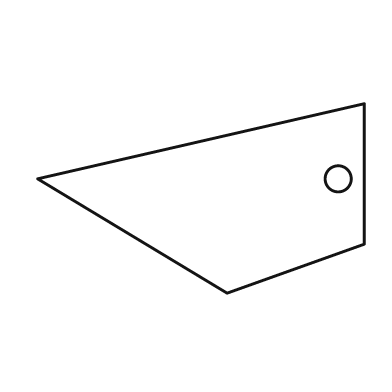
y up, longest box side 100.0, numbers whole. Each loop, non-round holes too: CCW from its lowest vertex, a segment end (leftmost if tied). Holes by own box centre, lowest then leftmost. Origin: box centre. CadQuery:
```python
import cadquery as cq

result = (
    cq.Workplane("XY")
    .moveTo(8.0, -29.0)
    .lineTo(50.0, -14.0)
    .lineTo(50.0, 29.0)
    .lineTo(-50.0, 6.0)
    .close()
    .moveTo(42.0, 6.0)
    .circle(4.0)
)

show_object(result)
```